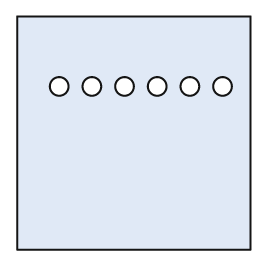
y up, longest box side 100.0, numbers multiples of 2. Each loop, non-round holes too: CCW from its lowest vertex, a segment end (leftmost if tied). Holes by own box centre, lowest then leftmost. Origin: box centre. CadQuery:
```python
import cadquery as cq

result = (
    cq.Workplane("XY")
    .moveTo(-50.0, -50.0)
    .lineTo(50.0, -50.0)
    .lineTo(50.0, 50.0)
    .lineTo(-50.0, 50.0)
    .close()
    .moveTo(-32.0, 20.0)
    .circle(4.0)
    .moveTo(-18.0, 20.0)
    .circle(4.0)
    .moveTo(-4.0, 20.0)
    .circle(4.0)
    .moveTo(10.0, 20.0)
    .circle(4.0)
    .moveTo(24.0, 20.0)
    .circle(4.0)
    .moveTo(38.0, 20.0)
    .circle(4.0)
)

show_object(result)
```